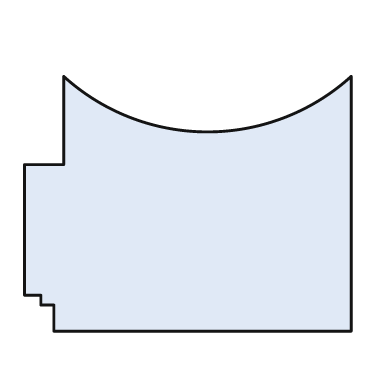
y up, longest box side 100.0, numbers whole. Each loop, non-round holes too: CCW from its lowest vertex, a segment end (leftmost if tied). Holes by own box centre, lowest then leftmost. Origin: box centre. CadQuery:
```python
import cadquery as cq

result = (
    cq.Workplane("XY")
    .moveTo(-41.0, -39.0)
    .lineTo(50.0, -39.0)
    .lineTo(50.0, 39.0)
    .threePointArc((6.0, 22.0), (-38.0, 39.0))
    .lineTo(-38.0, 12.0)
    .lineTo(-50.0, 12.0)
    .lineTo(-50.0, -28.0)
    .lineTo(-45.0, -28.0)
    .lineTo(-45.0, -31.0)
    .lineTo(-41.0, -31.0)
    .close()
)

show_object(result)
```